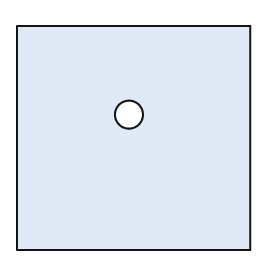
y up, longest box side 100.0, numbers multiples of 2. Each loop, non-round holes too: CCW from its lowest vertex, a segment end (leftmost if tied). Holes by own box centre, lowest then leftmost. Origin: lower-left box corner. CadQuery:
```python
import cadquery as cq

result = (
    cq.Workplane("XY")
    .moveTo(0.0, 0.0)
    .lineTo(100.0, 0.0)
    .lineTo(100.0, 96.0)
    .lineTo(0.0, 96.0)
    .close()
    .moveTo(48.0, 58.0)
    .circle(6.0)
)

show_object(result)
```